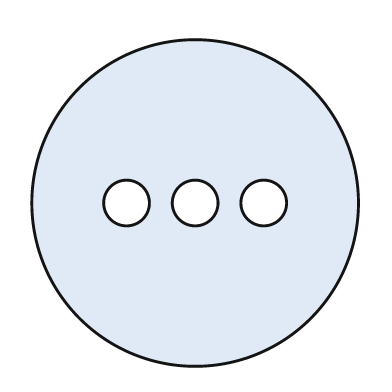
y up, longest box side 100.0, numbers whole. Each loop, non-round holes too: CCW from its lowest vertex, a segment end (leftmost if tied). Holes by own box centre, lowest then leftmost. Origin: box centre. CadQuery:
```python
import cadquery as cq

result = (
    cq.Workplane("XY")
    .moveTo(0.0, 0.0)
    .circle(50.0)
    .moveTo(-21.0, 0.0)
    .circle(7.0)
    .moveTo(0.0, 0.0)
    .circle(7.0)
    .moveTo(21.0, 0.0)
    .circle(7.0)
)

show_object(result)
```